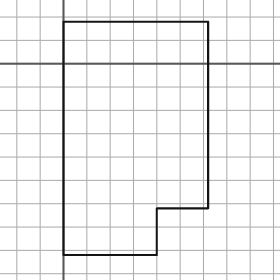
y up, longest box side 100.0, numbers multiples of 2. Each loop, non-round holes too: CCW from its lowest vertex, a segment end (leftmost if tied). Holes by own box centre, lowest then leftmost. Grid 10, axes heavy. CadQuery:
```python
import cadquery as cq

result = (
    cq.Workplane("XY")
    .moveTo(0.0, -82.0)
    .lineTo(40.0, -82.0)
    .lineTo(40.0, -62.0)
    .lineTo(62.0, -62.0)
    .lineTo(62.0, 18.0)
    .lineTo(0.0, 18.0)
    .close()
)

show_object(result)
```